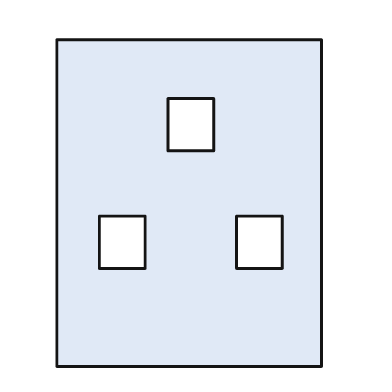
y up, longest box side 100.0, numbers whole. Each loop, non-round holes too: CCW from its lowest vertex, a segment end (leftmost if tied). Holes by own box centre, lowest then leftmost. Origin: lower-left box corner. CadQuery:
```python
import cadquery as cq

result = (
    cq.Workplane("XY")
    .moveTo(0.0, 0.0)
    .lineTo(81.0, 0.0)
    .lineTo(81.0, 100.0)
    .lineTo(0.0, 100.0)
    .close()
    .moveTo(13.0, 30.0)
    .lineTo(27.0, 30.0)
    .lineTo(27.0, 46.0)
    .lineTo(13.0, 46.0)
    .close()
    .moveTo(55.0, 30.0)
    .lineTo(69.0, 30.0)
    .lineTo(69.0, 46.0)
    .lineTo(55.0, 46.0)
    .close()
    .moveTo(34.0, 66.0)
    .lineTo(48.0, 66.0)
    .lineTo(48.0, 82.0)
    .lineTo(34.0, 82.0)
    .close()
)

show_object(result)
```